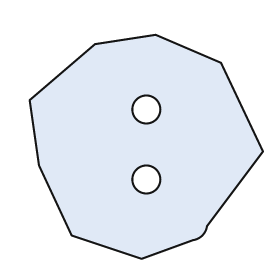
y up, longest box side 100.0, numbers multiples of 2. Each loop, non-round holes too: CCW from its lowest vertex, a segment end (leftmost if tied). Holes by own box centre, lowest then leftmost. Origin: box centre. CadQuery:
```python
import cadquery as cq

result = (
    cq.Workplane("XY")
    .moveTo(-2.0, -48.0)
    .lineTo(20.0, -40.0)
    .threePointArc((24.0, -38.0), (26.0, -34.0))
    .lineTo(50.0, -2.0)
    .lineTo(32.0, 36.0)
    .lineTo(4.0, 48.0)
    .lineTo(-22.0, 44.0)
    .lineTo(-50.0, 20.0)
    .lineTo(-46.0, -8.0)
    .lineTo(-32.0, -38.0)
    .close()
    .moveTo(0.0, -14.0)
    .circle(6.0)
    .moveTo(0.0, 16.0)
    .circle(6.0)
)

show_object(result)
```